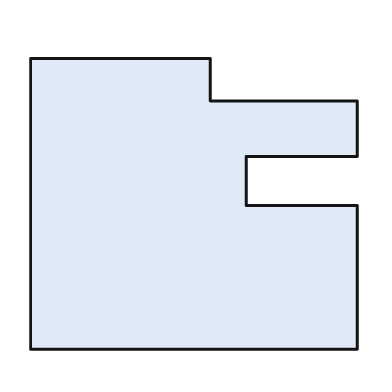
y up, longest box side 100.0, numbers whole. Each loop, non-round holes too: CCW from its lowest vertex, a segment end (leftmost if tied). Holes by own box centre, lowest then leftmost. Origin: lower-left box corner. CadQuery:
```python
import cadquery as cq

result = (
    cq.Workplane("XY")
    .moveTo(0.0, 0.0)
    .lineTo(100.0, 0.0)
    .lineTo(100.0, 44.0)
    .lineTo(66.0, 44.0)
    .lineTo(66.0, 59.0)
    .lineTo(100.0, 59.0)
    .lineTo(100.0, 76.0)
    .lineTo(55.0, 76.0)
    .lineTo(55.0, 89.0)
    .lineTo(0.0, 89.0)
    .close()
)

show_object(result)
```